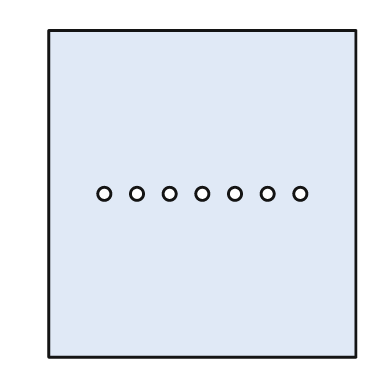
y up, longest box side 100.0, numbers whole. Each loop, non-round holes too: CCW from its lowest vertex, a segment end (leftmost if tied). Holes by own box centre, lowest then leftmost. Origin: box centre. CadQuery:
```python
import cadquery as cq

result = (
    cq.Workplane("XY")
    .moveTo(-47.0, -50.0)
    .lineTo(47.0, -50.0)
    .lineTo(47.0, 50.0)
    .lineTo(-47.0, 50.0)
    .close()
    .moveTo(-30.0, 0.0)
    .circle(2.0)
    .moveTo(-20.0, 0.0)
    .circle(2.0)
    .moveTo(-10.0, 0.0)
    .circle(2.0)
    .moveTo(0.0, 0.0)
    .circle(2.0)
    .moveTo(10.0, 0.0)
    .circle(2.0)
    .moveTo(20.0, 0.0)
    .circle(2.0)
    .moveTo(30.0, 0.0)
    .circle(2.0)
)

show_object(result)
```